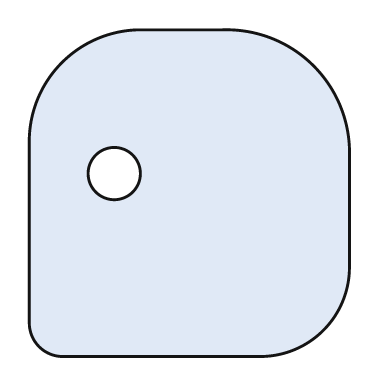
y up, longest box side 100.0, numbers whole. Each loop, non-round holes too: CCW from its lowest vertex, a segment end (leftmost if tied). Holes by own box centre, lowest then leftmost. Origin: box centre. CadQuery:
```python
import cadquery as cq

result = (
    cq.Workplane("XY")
    .moveTo(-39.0, -50.0)
    .lineTo(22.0, -50.0)
    .threePointArc((41.0, -42.0), (49.0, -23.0))
    .lineTo(49.0, 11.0)
    .threePointArc((38.0, 39.0), (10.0, 50.0))
    .lineTo(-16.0, 50.0)
    .threePointArc((-39.0, 40.0), (-49.0, 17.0))
    .lineTo(-49.0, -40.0)
    .threePointArc((-46.0, -47.0), (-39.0, -50.0))
    .close()
    .moveTo(-23.0, 6.0)
    .circle(8.0)
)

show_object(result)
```